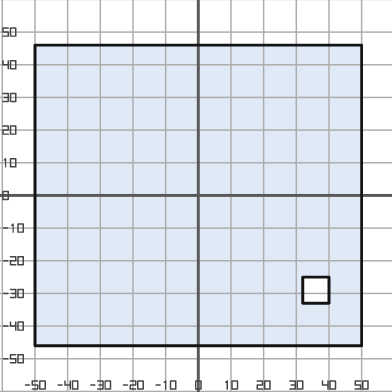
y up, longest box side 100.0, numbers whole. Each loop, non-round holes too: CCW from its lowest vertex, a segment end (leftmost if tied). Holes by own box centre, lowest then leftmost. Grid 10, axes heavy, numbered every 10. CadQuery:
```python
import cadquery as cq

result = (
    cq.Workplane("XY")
    .moveTo(-50.0, -46.0)
    .lineTo(50.0, -46.0)
    .lineTo(50.0, 46.0)
    .lineTo(-50.0, 46.0)
    .close()
    .moveTo(32.0, -33.0)
    .lineTo(40.0, -33.0)
    .lineTo(40.0, -25.0)
    .lineTo(32.0, -25.0)
    .close()
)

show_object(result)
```